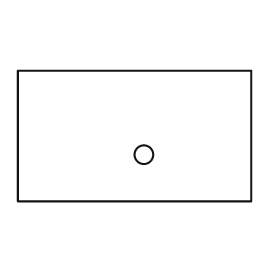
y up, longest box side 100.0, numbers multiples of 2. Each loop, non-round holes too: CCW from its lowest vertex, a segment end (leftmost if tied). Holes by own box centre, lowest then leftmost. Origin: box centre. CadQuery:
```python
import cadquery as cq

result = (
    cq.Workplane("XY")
    .moveTo(-50.0, -28.0)
    .lineTo(50.0, -28.0)
    .lineTo(50.0, 28.0)
    .lineTo(-50.0, 28.0)
    .close()
    .moveTo(4.0, -8.0)
    .circle(4.0)
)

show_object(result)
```